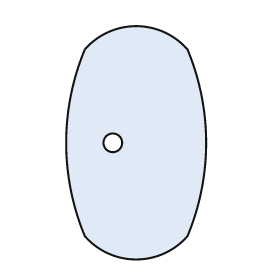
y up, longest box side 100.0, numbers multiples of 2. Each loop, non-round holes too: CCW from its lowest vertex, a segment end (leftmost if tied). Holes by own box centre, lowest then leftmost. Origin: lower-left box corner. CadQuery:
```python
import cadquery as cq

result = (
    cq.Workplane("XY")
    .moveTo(8.0, 10.0)
    .threePointArc((30.0, 0.0), (52.0, 10.0))
    .threePointArc((60.0, 50.0), (52.0, 90.0))
    .threePointArc((30.0, 100.0), (8.0, 90.0))
    .threePointArc((0.0, 50.0), (8.0, 10.0))
    .close()
    .moveTo(20.0, 50.0)
    .circle(4.0)
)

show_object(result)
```